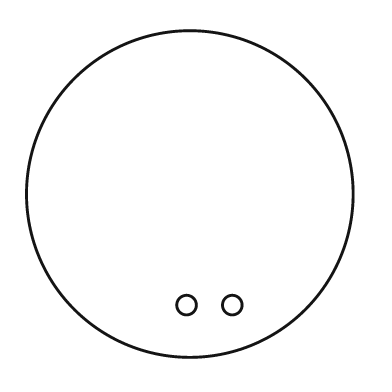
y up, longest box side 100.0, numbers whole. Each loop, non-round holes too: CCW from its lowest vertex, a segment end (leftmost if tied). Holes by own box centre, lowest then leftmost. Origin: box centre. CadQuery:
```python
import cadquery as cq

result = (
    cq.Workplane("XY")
    .moveTo(0.0, 0.0)
    .circle(50.0)
    .moveTo(-1.0, -34.0)
    .circle(3.0)
    .moveTo(13.0, -34.0)
    .circle(3.0)
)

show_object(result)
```